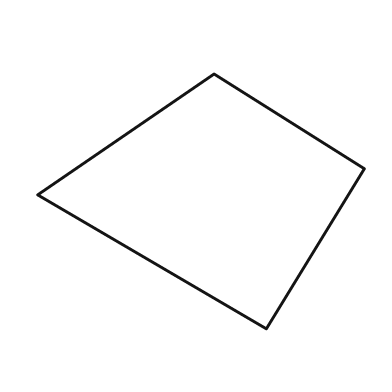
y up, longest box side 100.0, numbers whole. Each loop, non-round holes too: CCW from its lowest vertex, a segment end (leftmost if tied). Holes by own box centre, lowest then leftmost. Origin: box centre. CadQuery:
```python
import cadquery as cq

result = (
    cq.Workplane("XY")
    .moveTo(20.0, -39.0)
    .lineTo(50.0, 10.0)
    .lineTo(4.0, 39.0)
    .lineTo(-50.0, 2.0)
    .close()
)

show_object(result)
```